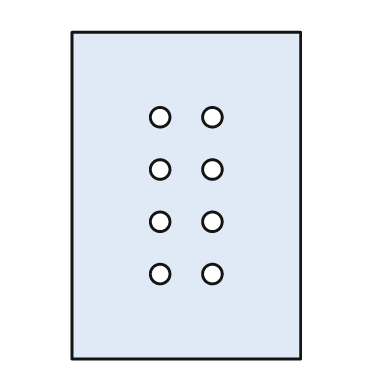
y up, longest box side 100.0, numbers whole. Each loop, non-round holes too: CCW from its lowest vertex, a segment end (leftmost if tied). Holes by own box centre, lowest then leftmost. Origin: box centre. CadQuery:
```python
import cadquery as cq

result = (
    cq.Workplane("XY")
    .moveTo(-35.0, -50.0)
    .lineTo(35.0, -50.0)
    .lineTo(35.0, 50.0)
    .lineTo(-35.0, 50.0)
    .close()
    .moveTo(-8.0, -24.0)
    .circle(3.0)
    .moveTo(8.0, -24.0)
    .circle(3.0)
    .moveTo(-8.0, -8.0)
    .circle(3.0)
    .moveTo(8.0, -8.0)
    .circle(3.0)
    .moveTo(-8.0, 8.0)
    .circle(3.0)
    .moveTo(8.0, 8.0)
    .circle(3.0)
    .moveTo(-8.0, 24.0)
    .circle(3.0)
    .moveTo(8.0, 24.0)
    .circle(3.0)
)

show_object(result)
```